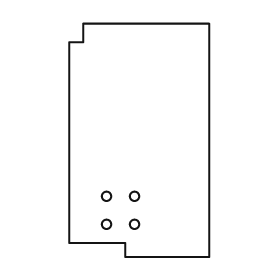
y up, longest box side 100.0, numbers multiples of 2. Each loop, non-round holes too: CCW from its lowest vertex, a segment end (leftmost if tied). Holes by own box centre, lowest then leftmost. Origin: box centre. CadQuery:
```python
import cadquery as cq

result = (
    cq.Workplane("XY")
    .moveTo(-6.0, -50.0)
    .lineTo(30.0, -50.0)
    .lineTo(30.0, 50.0)
    .lineTo(-24.0, 50.0)
    .lineTo(-24.0, 42.0)
    .lineTo(-30.0, 42.0)
    .lineTo(-30.0, -44.0)
    .lineTo(-6.0, -44.0)
    .close()
    .moveTo(-14.0, -36.0)
    .circle(2.0)
    .moveTo(-2.0, -36.0)
    .circle(2.0)
    .moveTo(-14.0, -24.0)
    .circle(2.0)
    .moveTo(-2.0, -24.0)
    .circle(2.0)
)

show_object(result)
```